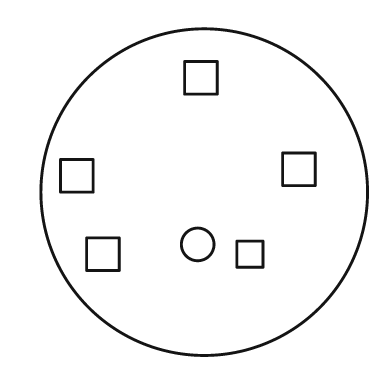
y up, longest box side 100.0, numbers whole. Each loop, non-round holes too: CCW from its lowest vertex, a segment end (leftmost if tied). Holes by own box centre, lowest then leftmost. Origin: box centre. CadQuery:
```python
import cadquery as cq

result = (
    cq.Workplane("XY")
    .moveTo(0.0, 0.0)
    .circle(50.0)
    .moveTo(-36.0, -24.0)
    .lineTo(-26.0, -24.0)
    .lineTo(-26.0, -14.0)
    .lineTo(-36.0, -14.0)
    .close()
    .moveTo(10.0, -23.0)
    .lineTo(18.0, -23.0)
    .lineTo(18.0, -15.0)
    .lineTo(10.0, -15.0)
    .close()
    .moveTo(-2.0, -16.0)
    .circle(5.0)
    .moveTo(-44.0, 0.0)
    .lineTo(-34.0, 0.0)
    .lineTo(-34.0, 10.0)
    .lineTo(-44.0, 10.0)
    .close()
    .moveTo(24.0, 2.0)
    .lineTo(34.0, 2.0)
    .lineTo(34.0, 12.0)
    .lineTo(24.0, 12.0)
    .close()
    .moveTo(-6.0, 30.0)
    .lineTo(4.0, 30.0)
    .lineTo(4.0, 40.0)
    .lineTo(-6.0, 40.0)
    .close()
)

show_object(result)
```